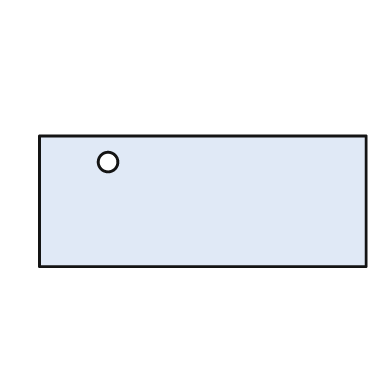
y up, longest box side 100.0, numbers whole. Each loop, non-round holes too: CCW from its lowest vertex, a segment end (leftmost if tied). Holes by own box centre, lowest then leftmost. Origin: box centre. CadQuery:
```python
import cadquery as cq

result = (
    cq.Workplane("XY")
    .moveTo(-50.0, -20.0)
    .lineTo(50.0, -20.0)
    .lineTo(50.0, 20.0)
    .lineTo(-50.0, 20.0)
    .close()
    .moveTo(-29.0, 12.0)
    .circle(3.0)
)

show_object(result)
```